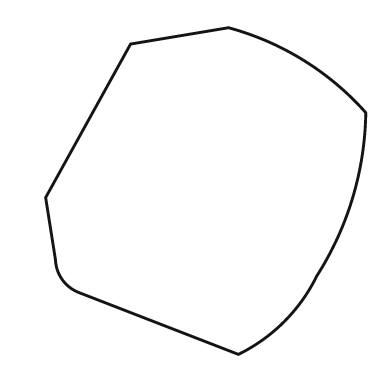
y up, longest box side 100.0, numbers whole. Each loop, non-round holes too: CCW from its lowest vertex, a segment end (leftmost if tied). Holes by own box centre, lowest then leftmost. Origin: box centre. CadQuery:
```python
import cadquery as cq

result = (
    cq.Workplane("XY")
    .moveTo(10.0, -50.0)
    .threePointArc((24.0, -40.0), (34.0, -26.0))
    .threePointArc((45.0, -2.0), (49.0, 24.0))
    .threePointArc((30.0, 40.0), (7.0, 50.0))
    .lineTo(-23.0, 45.0)
    .lineTo(-49.0, -2.0)
    .lineTo(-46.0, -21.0)
    .threePointArc((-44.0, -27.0), (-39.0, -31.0))
    .close()
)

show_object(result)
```